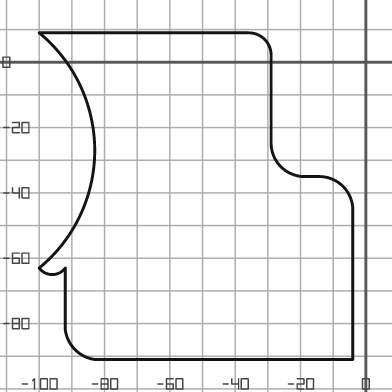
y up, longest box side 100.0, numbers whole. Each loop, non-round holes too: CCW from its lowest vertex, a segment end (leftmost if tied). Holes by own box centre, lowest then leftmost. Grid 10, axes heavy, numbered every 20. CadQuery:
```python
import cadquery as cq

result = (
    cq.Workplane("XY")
    .moveTo(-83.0, -91.0)
    .lineTo(-4.0, -91.0)
    .lineTo(-4.0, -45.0)
    .threePointArc((-7.0, -38.0), (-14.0, -35.0))
    .lineTo(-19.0, -35.0)
    .threePointArc((-26.0, -32.0), (-29.0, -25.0))
    .lineTo(-29.0, 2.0)
    .threePointArc((-31.0, 7.0), (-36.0, 9.0))
    .lineTo(-100.0, 9.0)
    .threePointArc((-83.0, -27.0), (-100.0, -63.0))
    .threePointArc((-96.0, -65.0), (-92.0, -63.0))
    .lineTo(-92.0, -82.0)
    .threePointArc((-89.0, -88.0), (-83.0, -91.0))
    .close()
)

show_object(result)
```